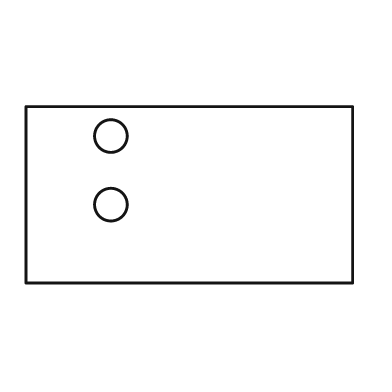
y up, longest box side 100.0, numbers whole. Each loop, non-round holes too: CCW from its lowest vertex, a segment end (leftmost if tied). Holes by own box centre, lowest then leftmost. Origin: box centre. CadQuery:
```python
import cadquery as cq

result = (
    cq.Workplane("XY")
    .moveTo(-50.0, -27.0)
    .lineTo(50.0, -27.0)
    .lineTo(50.0, 27.0)
    .lineTo(-50.0, 27.0)
    .close()
    .moveTo(-24.0, -3.0)
    .circle(5.0)
    .moveTo(-24.0, 18.0)
    .circle(5.0)
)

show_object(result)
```